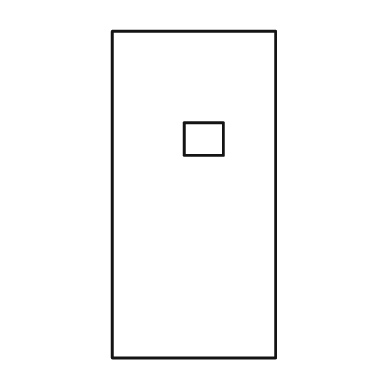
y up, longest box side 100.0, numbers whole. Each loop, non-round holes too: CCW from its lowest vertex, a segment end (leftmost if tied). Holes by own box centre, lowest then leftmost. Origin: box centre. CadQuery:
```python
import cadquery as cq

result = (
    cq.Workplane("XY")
    .moveTo(-25.0, -50.0)
    .lineTo(25.0, -50.0)
    .lineTo(25.0, 50.0)
    .lineTo(-25.0, 50.0)
    .close()
    .moveTo(-3.0, 12.0)
    .lineTo(9.0, 12.0)
    .lineTo(9.0, 22.0)
    .lineTo(-3.0, 22.0)
    .close()
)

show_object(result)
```